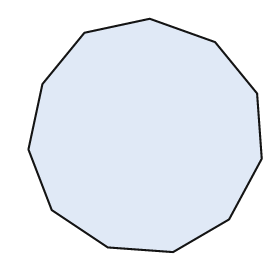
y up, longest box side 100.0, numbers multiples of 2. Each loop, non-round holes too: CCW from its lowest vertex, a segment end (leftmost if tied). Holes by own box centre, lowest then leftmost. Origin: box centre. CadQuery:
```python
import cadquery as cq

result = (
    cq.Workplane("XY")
    .moveTo(12.0, -50.0)
    .lineTo(36.0, -36.0)
    .lineTo(50.0, -10.0)
    .lineTo(48.0, 18.0)
    .lineTo(30.0, 40.0)
    .lineTo(2.0, 50.0)
    .lineTo(-26.0, 44.0)
    .lineTo(-44.0, 22.0)
    .lineTo(-50.0, -6.0)
    .lineTo(-40.0, -32.0)
    .lineTo(-16.0, -48.0)
    .close()
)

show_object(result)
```